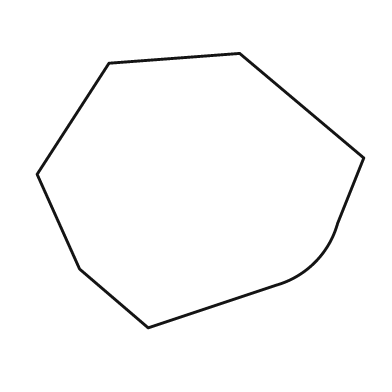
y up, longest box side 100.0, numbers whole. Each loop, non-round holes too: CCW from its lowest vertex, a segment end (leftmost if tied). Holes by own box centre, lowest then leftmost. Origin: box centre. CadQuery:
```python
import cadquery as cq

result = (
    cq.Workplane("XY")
    .moveTo(-16.0, -42.0)
    .lineTo(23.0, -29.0)
    .threePointArc((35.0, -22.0), (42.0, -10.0))
    .lineTo(50.0, 10.0)
    .lineTo(12.0, 42.0)
    .lineTo(-28.0, 39.0)
    .lineTo(-50.0, 5.0)
    .lineTo(-37.0, -24.0)
    .close()
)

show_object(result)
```